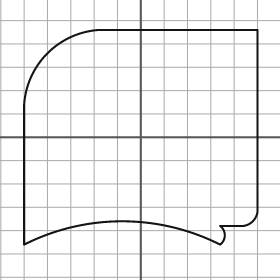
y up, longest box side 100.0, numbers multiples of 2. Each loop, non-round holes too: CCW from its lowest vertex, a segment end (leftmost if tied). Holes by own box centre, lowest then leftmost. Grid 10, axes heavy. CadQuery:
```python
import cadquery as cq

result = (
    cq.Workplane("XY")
    .moveTo(-50.0, -46.0)
    .threePointArc((-8.0, -36.0), (34.0, -46.0))
    .threePointArc((36.0, -42.0), (34.0, -38.0))
    .lineTo(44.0, -38.0)
    .threePointArc((48.0, -36.0), (50.0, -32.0))
    .lineTo(50.0, 46.0)
    .lineTo(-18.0, 46.0)
    .threePointArc((-40.0, 36.0), (-50.0, 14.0))
    .close()
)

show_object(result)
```